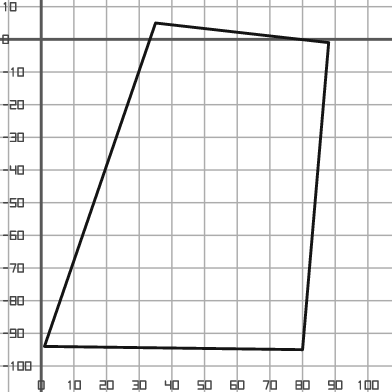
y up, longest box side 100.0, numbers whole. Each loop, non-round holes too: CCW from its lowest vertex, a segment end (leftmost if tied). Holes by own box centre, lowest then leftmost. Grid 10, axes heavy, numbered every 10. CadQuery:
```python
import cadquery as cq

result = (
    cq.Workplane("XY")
    .moveTo(80.0, -95.0)
    .lineTo(88.0, -1.0)
    .lineTo(35.0, 5.0)
    .lineTo(1.0, -94.0)
    .close()
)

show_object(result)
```